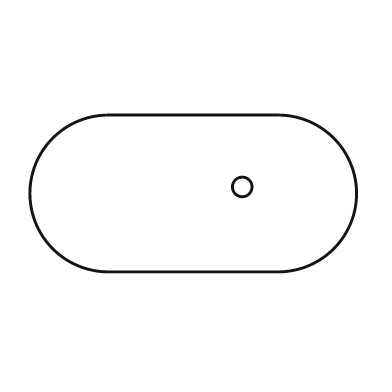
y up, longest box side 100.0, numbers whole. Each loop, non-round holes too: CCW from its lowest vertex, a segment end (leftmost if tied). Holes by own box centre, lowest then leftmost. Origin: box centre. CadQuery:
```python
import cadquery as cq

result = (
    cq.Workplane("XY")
    .moveTo(-26.0, -24.0)
    .lineTo(26.0, -24.0)
    .threePointArc((50.0, 0.0), (26.0, 24.0))
    .lineTo(-26.0, 24.0)
    .threePointArc((-50.0, 0.0), (-26.0, -24.0))
    .close()
    .moveTo(15.0, 2.0)
    .circle(3.0)
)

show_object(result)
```